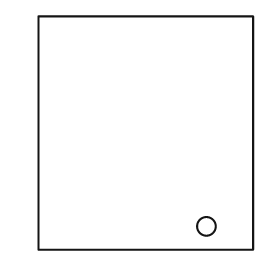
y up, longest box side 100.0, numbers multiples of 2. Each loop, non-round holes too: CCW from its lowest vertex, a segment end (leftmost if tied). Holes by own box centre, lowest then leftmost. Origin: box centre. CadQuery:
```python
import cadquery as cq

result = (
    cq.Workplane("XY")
    .moveTo(-46.0, -50.0)
    .lineTo(46.0, -50.0)
    .lineTo(46.0, 50.0)
    .lineTo(-46.0, 50.0)
    .close()
    .moveTo(26.0, -40.0)
    .circle(4.0)
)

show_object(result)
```